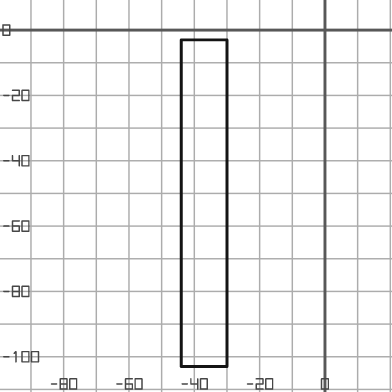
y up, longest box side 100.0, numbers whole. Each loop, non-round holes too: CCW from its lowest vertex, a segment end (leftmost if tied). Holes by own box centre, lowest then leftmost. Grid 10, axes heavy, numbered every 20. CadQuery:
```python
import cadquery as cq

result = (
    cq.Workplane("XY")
    .moveTo(-44.0, -103.0)
    .lineTo(-30.0, -103.0)
    .lineTo(-30.0, -3.0)
    .lineTo(-44.0, -3.0)
    .close()
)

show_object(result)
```